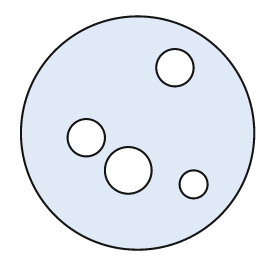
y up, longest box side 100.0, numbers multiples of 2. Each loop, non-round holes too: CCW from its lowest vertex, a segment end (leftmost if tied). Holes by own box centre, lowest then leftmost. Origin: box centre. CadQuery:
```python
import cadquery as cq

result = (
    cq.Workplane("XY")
    .moveTo(0.0, 0.0)
    .circle(50.0)
    .moveTo(24.0, -22.0)
    .circle(6.0)
    .moveTo(-4.0, -16.0)
    .circle(10.0)
    .moveTo(-22.0, -2.0)
    .circle(8.0)
    .moveTo(16.0, 28.0)
    .circle(8.0)
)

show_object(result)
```